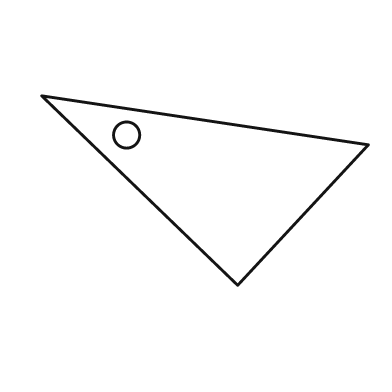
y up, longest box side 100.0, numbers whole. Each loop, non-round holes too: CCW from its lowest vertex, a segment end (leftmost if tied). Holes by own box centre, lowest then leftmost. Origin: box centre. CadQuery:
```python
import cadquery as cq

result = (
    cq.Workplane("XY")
    .moveTo(10.0, -29.0)
    .lineTo(50.0, 14.0)
    .lineTo(-50.0, 29.0)
    .close()
    .moveTo(-24.0, 17.0)
    .circle(4.0)
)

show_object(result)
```